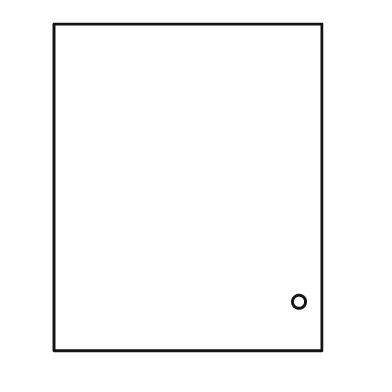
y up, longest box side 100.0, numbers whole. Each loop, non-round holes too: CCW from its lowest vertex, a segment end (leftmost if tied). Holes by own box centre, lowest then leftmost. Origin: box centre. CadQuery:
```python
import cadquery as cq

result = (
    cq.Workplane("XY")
    .moveTo(-41.0, -50.0)
    .lineTo(41.0, -50.0)
    .lineTo(41.0, 50.0)
    .lineTo(-41.0, 50.0)
    .close()
    .moveTo(34.0, -35.0)
    .circle(2.0)
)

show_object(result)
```